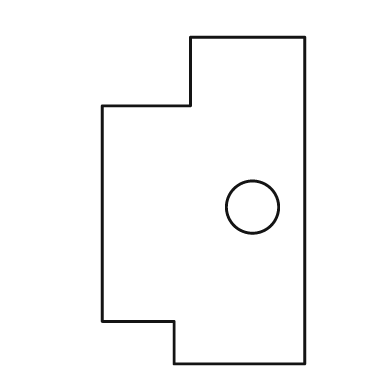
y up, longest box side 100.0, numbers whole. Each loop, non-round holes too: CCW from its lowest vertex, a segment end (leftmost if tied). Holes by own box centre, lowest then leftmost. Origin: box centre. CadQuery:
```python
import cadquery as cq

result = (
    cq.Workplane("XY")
    .moveTo(-9.0, -50.0)
    .lineTo(31.0, -50.0)
    .lineTo(31.0, 50.0)
    .lineTo(-4.0, 50.0)
    .lineTo(-4.0, 29.0)
    .lineTo(-31.0, 29.0)
    .lineTo(-31.0, -37.0)
    .lineTo(-9.0, -37.0)
    .close()
    .moveTo(15.0, -2.0)
    .circle(8.0)
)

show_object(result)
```